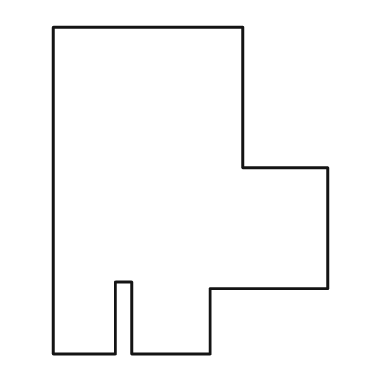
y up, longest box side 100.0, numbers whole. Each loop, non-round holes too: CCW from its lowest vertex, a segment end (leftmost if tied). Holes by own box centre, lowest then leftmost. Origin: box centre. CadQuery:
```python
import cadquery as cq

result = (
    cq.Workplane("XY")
    .moveTo(-42.0, -50.0)
    .lineTo(-23.0, -50.0)
    .lineTo(-23.0, -28.0)
    .lineTo(-18.0, -28.0)
    .lineTo(-18.0, -50.0)
    .lineTo(6.0, -50.0)
    .lineTo(6.0, -30.0)
    .lineTo(42.0, -30.0)
    .lineTo(42.0, 7.0)
    .lineTo(16.0, 7.0)
    .lineTo(16.0, 50.0)
    .lineTo(-42.0, 50.0)
    .close()
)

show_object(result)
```